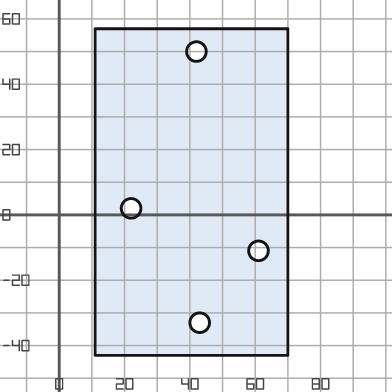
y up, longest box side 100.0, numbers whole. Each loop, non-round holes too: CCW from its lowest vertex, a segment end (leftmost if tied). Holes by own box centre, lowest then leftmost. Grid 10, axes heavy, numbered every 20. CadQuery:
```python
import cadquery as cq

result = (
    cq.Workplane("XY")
    .moveTo(11.0, -43.0)
    .lineTo(70.0, -43.0)
    .lineTo(70.0, 57.0)
    .lineTo(11.0, 57.0)
    .close()
    .moveTo(43.0, -33.0)
    .circle(3.0)
    .moveTo(61.0, -11.0)
    .circle(3.0)
    .moveTo(22.0, 2.0)
    .circle(3.0)
    .moveTo(42.0, 50.0)
    .circle(3.0)
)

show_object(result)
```